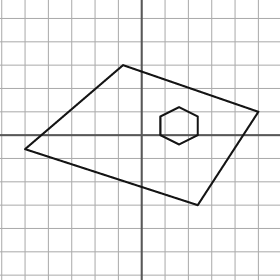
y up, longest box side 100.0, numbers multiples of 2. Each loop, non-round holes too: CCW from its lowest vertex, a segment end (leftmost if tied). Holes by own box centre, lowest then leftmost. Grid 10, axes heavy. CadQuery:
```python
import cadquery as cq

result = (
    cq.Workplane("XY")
    .moveTo(24.0, -30.0)
    .lineTo(50.0, 10.0)
    .lineTo(-8.0, 30.0)
    .lineTo(-50.0, -6.0)
    .close()
    .moveTo(16.0, -4.0)
    .lineTo(24.0, 0.0)
    .lineTo(24.0, 8.0)
    .lineTo(16.0, 12.0)
    .lineTo(8.0, 8.0)
    .lineTo(8.0, 0.0)
    .close()
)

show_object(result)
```